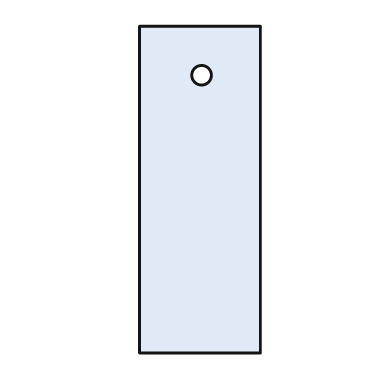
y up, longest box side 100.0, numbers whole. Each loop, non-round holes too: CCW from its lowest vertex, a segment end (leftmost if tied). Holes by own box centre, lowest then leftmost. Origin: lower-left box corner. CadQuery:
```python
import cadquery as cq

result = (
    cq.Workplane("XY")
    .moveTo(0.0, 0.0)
    .lineTo(37.0, 0.0)
    .lineTo(37.0, 100.0)
    .lineTo(0.0, 100.0)
    .close()
    .moveTo(19.0, 85.0)
    .circle(3.0)
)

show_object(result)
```